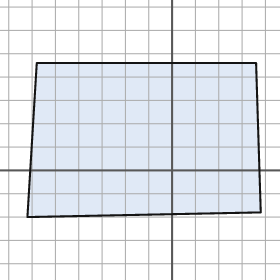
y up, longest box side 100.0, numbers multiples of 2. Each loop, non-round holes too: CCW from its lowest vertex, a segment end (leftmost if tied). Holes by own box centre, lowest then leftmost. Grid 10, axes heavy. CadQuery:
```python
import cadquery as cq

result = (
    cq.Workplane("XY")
    .moveTo(-62.0, -20.0)
    .lineTo(38.0, -18.0)
    .lineTo(36.0, 46.0)
    .lineTo(-58.0, 46.0)
    .close()
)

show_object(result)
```